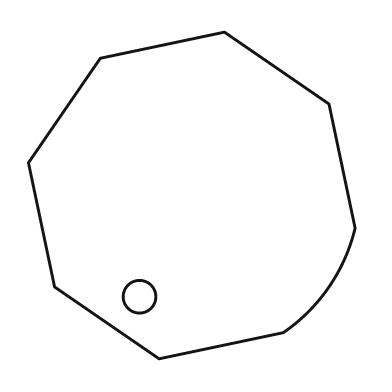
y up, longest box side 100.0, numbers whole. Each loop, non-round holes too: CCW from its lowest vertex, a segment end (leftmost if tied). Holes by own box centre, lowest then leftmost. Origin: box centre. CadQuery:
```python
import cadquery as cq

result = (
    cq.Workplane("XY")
    .moveTo(-10.0, -50.0)
    .lineTo(28.0, -42.0)
    .threePointArc((42.0, -28.0), (50.0, -10.0))
    .lineTo(42.0, 28.0)
    .lineTo(10.0, 50.0)
    .lineTo(-28.0, 42.0)
    .lineTo(-50.0, 10.0)
    .lineTo(-42.0, -28.0)
    .close()
    .moveTo(-16.0, -31.0)
    .circle(5.0)
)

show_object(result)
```